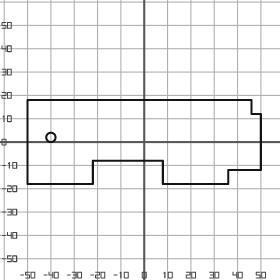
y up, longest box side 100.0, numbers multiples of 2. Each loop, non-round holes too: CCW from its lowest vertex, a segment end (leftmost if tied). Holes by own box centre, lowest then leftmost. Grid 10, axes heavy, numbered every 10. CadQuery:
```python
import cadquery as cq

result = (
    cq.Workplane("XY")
    .moveTo(-50.0, -18.0)
    .lineTo(-22.0, -18.0)
    .lineTo(-22.0, -8.0)
    .lineTo(8.0, -8.0)
    .lineTo(8.0, -18.0)
    .lineTo(36.0, -18.0)
    .lineTo(36.0, -12.0)
    .lineTo(50.0, -12.0)
    .lineTo(50.0, 12.0)
    .lineTo(46.0, 12.0)
    .lineTo(46.0, 18.0)
    .lineTo(-50.0, 18.0)
    .close()
    .moveTo(-40.0, 2.0)
    .circle(2.0)
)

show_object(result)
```